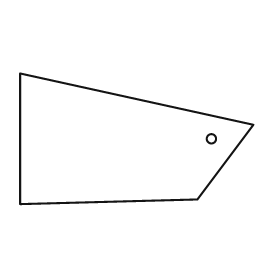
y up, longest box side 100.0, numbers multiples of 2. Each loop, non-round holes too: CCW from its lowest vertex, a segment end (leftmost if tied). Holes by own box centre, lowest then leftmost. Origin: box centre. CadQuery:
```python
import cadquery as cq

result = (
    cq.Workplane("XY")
    .moveTo(-50.0, -28.0)
    .lineTo(26.0, -26.0)
    .lineTo(50.0, 6.0)
    .lineTo(-50.0, 28.0)
    .close()
    .moveTo(32.0, 0.0)
    .circle(2.0)
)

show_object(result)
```